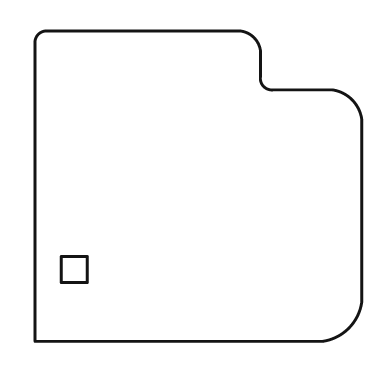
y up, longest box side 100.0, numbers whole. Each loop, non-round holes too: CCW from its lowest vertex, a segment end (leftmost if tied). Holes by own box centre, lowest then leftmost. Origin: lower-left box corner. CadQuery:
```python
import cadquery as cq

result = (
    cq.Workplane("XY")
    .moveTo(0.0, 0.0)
    .lineTo(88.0, 0.0)
    .threePointArc((96.0, 4.0), (100.0, 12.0))
    .lineTo(100.0, 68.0)
    .threePointArc((97.0, 74.0), (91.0, 77.0))
    .lineTo(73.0, 77.0)
    .threePointArc((70.0, 78.0), (69.0, 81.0))
    .lineTo(69.0, 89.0)
    .threePointArc((67.0, 93.0), (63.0, 95.0))
    .lineTo(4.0, 95.0)
    .threePointArc((1.0, 94.0), (0.0, 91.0))
    .close()
    .moveTo(8.0, 18.0)
    .lineTo(16.0, 18.0)
    .lineTo(16.0, 26.0)
    .lineTo(8.0, 26.0)
    .close()
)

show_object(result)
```